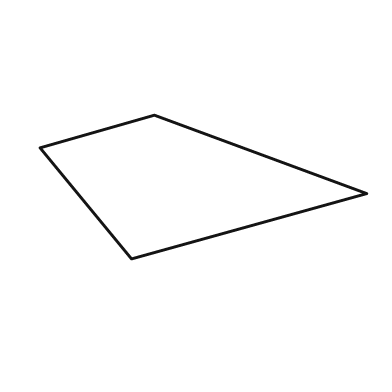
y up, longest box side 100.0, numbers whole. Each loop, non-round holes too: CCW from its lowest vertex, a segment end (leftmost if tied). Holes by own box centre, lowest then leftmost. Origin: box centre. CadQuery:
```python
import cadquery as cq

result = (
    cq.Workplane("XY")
    .moveTo(-22.0, -22.0)
    .lineTo(50.0, -2.0)
    .lineTo(-15.0, 22.0)
    .lineTo(-50.0, 12.0)
    .close()
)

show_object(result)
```